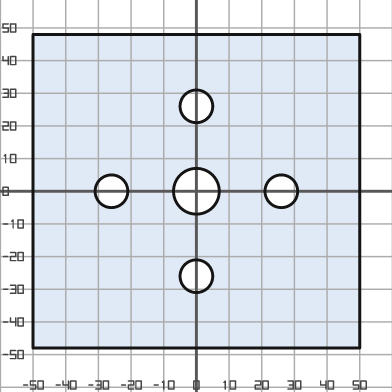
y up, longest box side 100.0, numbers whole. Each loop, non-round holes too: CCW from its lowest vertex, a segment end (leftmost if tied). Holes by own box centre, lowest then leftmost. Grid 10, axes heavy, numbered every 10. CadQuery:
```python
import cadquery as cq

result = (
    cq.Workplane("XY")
    .moveTo(-50.0, -48.0)
    .lineTo(50.0, -48.0)
    .lineTo(50.0, 48.0)
    .lineTo(-50.0, 48.0)
    .close()
    .moveTo(0.0, -26.0)
    .circle(5.0)
    .moveTo(-26.0, 0.0)
    .circle(5.0)
    .moveTo(0.0, 0.0)
    .circle(7.0)
    .moveTo(26.0, 0.0)
    .circle(5.0)
    .moveTo(0.0, 26.0)
    .circle(5.0)
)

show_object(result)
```